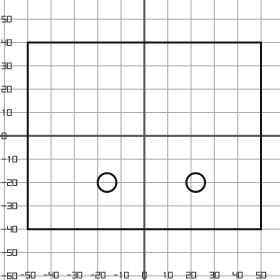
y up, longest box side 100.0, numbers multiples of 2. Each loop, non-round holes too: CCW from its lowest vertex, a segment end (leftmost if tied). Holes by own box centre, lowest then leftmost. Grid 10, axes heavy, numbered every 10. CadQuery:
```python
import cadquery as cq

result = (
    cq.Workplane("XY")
    .moveTo(-50.0, -40.0)
    .lineTo(50.0, -40.0)
    .lineTo(50.0, 40.0)
    .lineTo(-50.0, 40.0)
    .close()
    .moveTo(-16.0, -20.0)
    .circle(4.0)
    .moveTo(22.0, -20.0)
    .circle(4.0)
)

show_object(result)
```